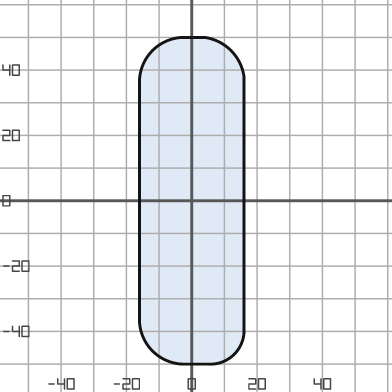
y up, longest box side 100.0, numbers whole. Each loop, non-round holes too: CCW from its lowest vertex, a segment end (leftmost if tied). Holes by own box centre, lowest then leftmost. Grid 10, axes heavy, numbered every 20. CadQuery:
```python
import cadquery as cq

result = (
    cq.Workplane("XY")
    .moveTo(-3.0, -50.0)
    .lineTo(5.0, -50.0)
    .threePointArc((13.0, -47.0), (16.0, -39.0))
    .lineTo(16.0, 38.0)
    .threePointArc((12.0, 46.0), (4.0, 50.0))
    .lineTo(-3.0, 50.0)
    .threePointArc((-12.0, 46.0), (-16.0, 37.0))
    .lineTo(-16.0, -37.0)
    .threePointArc((-12.0, -46.0), (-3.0, -50.0))
    .close()
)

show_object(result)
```